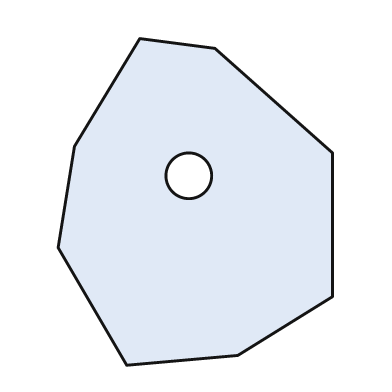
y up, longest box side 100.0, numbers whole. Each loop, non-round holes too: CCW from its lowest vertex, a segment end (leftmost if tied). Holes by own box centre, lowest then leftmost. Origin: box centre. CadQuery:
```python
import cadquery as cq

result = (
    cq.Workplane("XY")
    .moveTo(-21.0, -50.0)
    .lineTo(13.0, -47.0)
    .lineTo(42.0, -29.0)
    .lineTo(42.0, 15.0)
    .lineTo(6.0, 47.0)
    .lineTo(-17.0, 50.0)
    .lineTo(-37.0, 17.0)
    .lineTo(-42.0, -14.0)
    .close()
    .moveTo(-2.0, 8.0)
    .circle(7.0)
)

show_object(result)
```